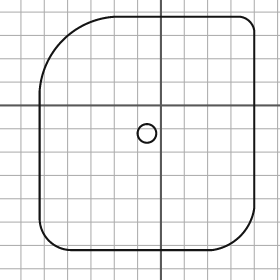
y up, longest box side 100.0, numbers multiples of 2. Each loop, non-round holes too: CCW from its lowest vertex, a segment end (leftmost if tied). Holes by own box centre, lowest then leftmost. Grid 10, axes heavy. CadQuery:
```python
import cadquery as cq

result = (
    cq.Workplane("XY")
    .moveTo(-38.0, -62.0)
    .lineTo(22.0, -62.0)
    .threePointArc((34.0, -56.0), (40.0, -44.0))
    .lineTo(40.0, 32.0)
    .threePointArc((38.0, 36.0), (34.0, 38.0))
    .lineTo(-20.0, 38.0)
    .threePointArc((-42.0, 28.0), (-52.0, 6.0))
    .lineTo(-52.0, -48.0)
    .threePointArc((-48.0, -58.0), (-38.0, -62.0))
    .close()
    .moveTo(-6.0, -12.0)
    .circle(4.0)
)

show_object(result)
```